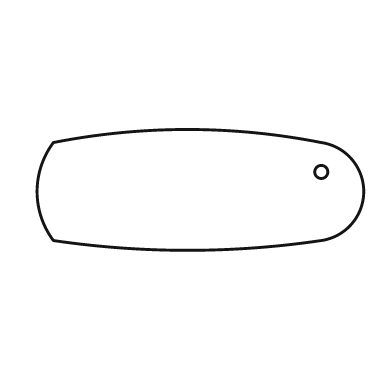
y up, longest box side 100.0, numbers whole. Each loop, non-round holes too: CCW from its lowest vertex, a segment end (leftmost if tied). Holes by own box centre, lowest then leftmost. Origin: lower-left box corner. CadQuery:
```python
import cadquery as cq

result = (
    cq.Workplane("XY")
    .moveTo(5.0, 3.0)
    .threePointArc((46.0, 0.0), (87.0, 3.0))
    .threePointArc((100.0, 18.0), (87.0, 33.0))
    .threePointArc((46.0, 37.0), (5.0, 33.0))
    .threePointArc((0.0, 18.0), (5.0, 3.0))
    .close()
    .moveTo(87.0, 24.0)
    .circle(2.0)
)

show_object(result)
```